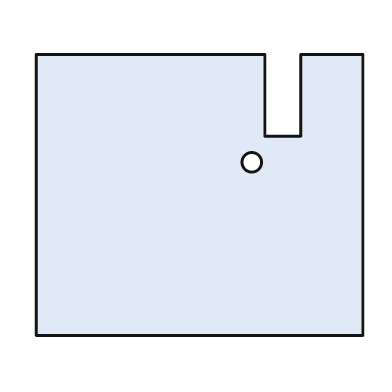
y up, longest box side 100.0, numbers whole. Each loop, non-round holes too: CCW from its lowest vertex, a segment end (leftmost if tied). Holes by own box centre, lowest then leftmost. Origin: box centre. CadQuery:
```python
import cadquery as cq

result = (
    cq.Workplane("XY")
    .moveTo(-50.0, -43.0)
    .lineTo(50.0, -43.0)
    .lineTo(50.0, 43.0)
    .lineTo(31.0, 43.0)
    .lineTo(31.0, 18.0)
    .lineTo(20.0, 18.0)
    .lineTo(20.0, 43.0)
    .lineTo(-50.0, 43.0)
    .close()
    .moveTo(16.0, 10.0)
    .circle(3.0)
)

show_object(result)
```